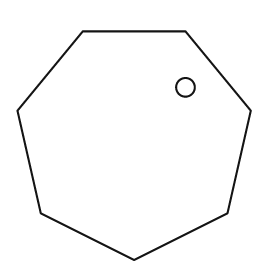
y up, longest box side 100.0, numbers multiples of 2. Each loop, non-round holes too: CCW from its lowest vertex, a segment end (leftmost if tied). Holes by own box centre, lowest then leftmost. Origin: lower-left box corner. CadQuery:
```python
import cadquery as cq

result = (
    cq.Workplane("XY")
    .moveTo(50.0, 0.0)
    .lineTo(90.0, 20.0)
    .lineTo(100.0, 64.0)
    .lineTo(72.0, 98.0)
    .lineTo(28.0, 98.0)
    .lineTo(0.0, 64.0)
    .lineTo(10.0, 20.0)
    .close()
    .moveTo(72.0, 74.0)
    .circle(4.0)
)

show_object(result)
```